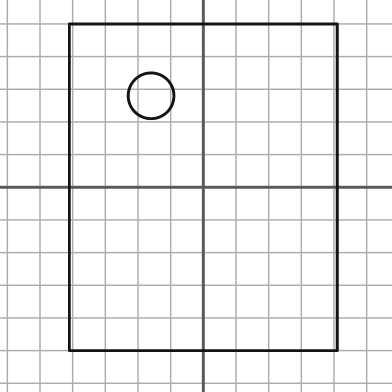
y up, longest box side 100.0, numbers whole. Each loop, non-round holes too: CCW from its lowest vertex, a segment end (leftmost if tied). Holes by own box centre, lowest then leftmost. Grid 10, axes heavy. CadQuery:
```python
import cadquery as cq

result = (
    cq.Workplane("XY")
    .moveTo(-41.0, -50.0)
    .lineTo(41.0, -50.0)
    .lineTo(41.0, 50.0)
    .lineTo(-41.0, 50.0)
    .close()
    .moveTo(-16.0, 28.0)
    .circle(7.0)
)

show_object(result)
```